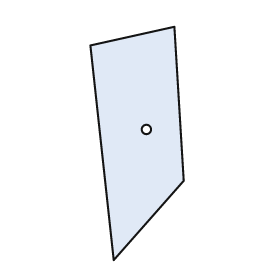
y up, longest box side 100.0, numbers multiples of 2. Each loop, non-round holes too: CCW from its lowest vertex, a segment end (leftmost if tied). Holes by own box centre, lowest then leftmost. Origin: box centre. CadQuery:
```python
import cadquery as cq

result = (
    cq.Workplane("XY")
    .moveTo(-10.0, -50.0)
    .lineTo(20.0, -16.0)
    .lineTo(16.0, 50.0)
    .lineTo(-20.0, 42.0)
    .close()
    .moveTo(4.0, 6.0)
    .circle(2.0)
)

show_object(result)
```